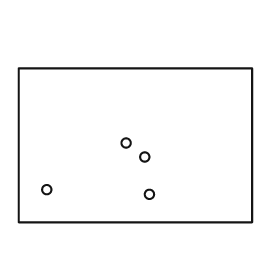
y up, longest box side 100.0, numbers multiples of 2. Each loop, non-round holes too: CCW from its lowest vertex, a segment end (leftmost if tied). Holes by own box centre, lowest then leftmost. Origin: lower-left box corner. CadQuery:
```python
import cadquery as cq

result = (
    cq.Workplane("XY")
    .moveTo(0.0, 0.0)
    .lineTo(100.0, 0.0)
    .lineTo(100.0, 66.0)
    .lineTo(0.0, 66.0)
    .close()
    .moveTo(56.0, 12.0)
    .circle(2.0)
    .moveTo(12.0, 14.0)
    .circle(2.0)
    .moveTo(54.0, 28.0)
    .circle(2.0)
    .moveTo(46.0, 34.0)
    .circle(2.0)
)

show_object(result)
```